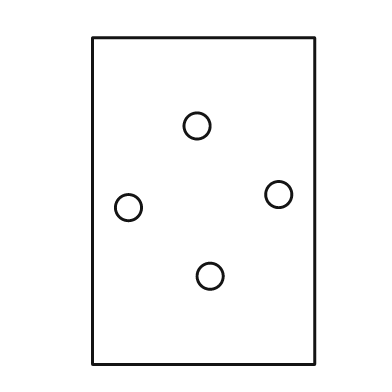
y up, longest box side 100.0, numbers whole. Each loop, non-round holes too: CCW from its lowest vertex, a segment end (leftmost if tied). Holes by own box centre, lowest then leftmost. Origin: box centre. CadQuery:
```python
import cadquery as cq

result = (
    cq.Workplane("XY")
    .moveTo(-34.0, -50.0)
    .lineTo(34.0, -50.0)
    .lineTo(34.0, 50.0)
    .lineTo(-34.0, 50.0)
    .close()
    .moveTo(2.0, -23.0)
    .circle(4.0)
    .moveTo(-23.0, -2.0)
    .circle(4.0)
    .moveTo(23.0, 2.0)
    .circle(4.0)
    .moveTo(-2.0, 23.0)
    .circle(4.0)
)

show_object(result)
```